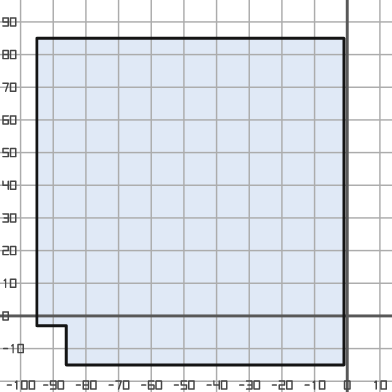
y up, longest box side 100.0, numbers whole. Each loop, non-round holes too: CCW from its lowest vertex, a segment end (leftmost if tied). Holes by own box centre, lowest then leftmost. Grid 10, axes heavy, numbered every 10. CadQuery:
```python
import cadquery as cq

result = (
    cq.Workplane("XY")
    .moveTo(-86.0, -15.0)
    .lineTo(-1.0, -15.0)
    .lineTo(-1.0, 85.0)
    .lineTo(-95.0, 85.0)
    .lineTo(-95.0, -3.0)
    .lineTo(-86.0, -3.0)
    .close()
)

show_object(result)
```